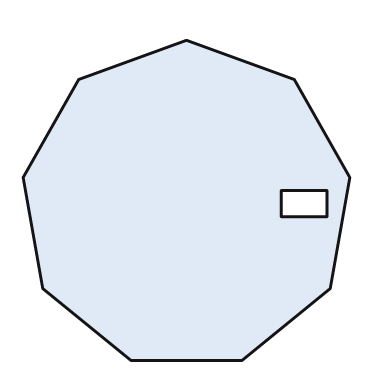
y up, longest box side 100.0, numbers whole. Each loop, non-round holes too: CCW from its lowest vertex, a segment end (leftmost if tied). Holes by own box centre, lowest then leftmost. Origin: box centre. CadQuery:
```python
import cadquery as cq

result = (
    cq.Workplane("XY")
    .moveTo(-17.0, -49.0)
    .lineTo(17.0, -49.0)
    .lineTo(44.0, -27.0)
    .lineTo(50.0, 7.0)
    .lineTo(33.0, 37.0)
    .lineTo(0.0, 49.0)
    .lineTo(-33.0, 37.0)
    .lineTo(-50.0, 7.0)
    .lineTo(-44.0, -27.0)
    .close()
    .moveTo(29.0, -5.0)
    .lineTo(43.0, -5.0)
    .lineTo(43.0, 3.0)
    .lineTo(29.0, 3.0)
    .close()
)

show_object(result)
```